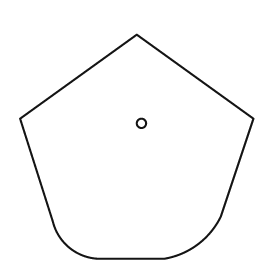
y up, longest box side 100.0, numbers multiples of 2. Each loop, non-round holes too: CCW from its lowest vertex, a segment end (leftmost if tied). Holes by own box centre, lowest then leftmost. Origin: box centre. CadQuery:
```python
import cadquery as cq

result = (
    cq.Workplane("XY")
    .moveTo(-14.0, -48.0)
    .lineTo(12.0, -48.0)
    .threePointArc((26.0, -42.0), (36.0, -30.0))
    .lineTo(50.0, 12.0)
    .lineTo(0.0, 48.0)
    .lineTo(-50.0, 12.0)
    .lineTo(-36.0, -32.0)
    .threePointArc((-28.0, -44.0), (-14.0, -48.0))
    .close()
    .moveTo(2.0, 10.0)
    .circle(2.0)
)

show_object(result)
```